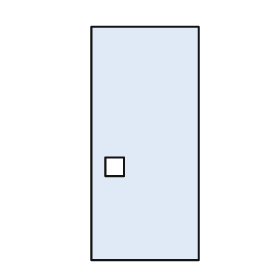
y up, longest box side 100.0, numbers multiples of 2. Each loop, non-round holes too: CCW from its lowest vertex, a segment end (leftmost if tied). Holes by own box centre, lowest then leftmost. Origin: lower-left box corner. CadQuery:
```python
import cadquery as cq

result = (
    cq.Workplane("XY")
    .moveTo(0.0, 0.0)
    .lineTo(46.0, 0.0)
    .lineTo(46.0, 100.0)
    .lineTo(0.0, 100.0)
    .close()
    .moveTo(6.0, 36.0)
    .lineTo(14.0, 36.0)
    .lineTo(14.0, 44.0)
    .lineTo(6.0, 44.0)
    .close()
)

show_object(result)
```